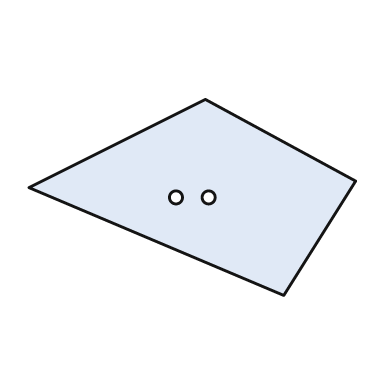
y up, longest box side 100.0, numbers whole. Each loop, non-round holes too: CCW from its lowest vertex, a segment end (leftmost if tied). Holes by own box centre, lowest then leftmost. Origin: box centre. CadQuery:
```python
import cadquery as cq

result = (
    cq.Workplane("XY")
    .moveTo(28.0, -30.0)
    .lineTo(50.0, 5.0)
    .lineTo(4.0, 30.0)
    .lineTo(-50.0, 3.0)
    .close()
    .moveTo(-5.0, 0.0)
    .circle(2.0)
    .moveTo(5.0, 0.0)
    .circle(2.0)
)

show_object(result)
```